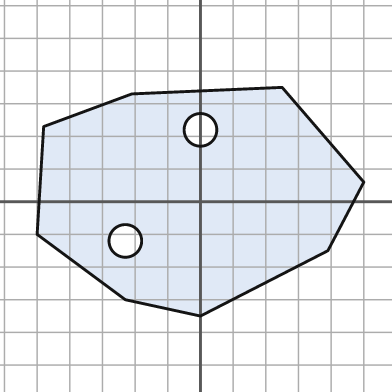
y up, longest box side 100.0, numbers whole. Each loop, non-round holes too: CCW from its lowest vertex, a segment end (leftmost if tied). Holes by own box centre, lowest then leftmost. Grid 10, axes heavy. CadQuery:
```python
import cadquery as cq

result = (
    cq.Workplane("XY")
    .moveTo(0.0, -35.0)
    .lineTo(39.0, -15.0)
    .lineTo(50.0, 6.0)
    .lineTo(25.0, 35.0)
    .lineTo(-21.0, 33.0)
    .lineTo(-48.0, 23.0)
    .lineTo(-50.0, -10.0)
    .lineTo(-23.0, -30.0)
    .close()
    .moveTo(-23.0, -12.0)
    .circle(5.0)
    .moveTo(0.0, 22.0)
    .circle(5.0)
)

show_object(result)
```